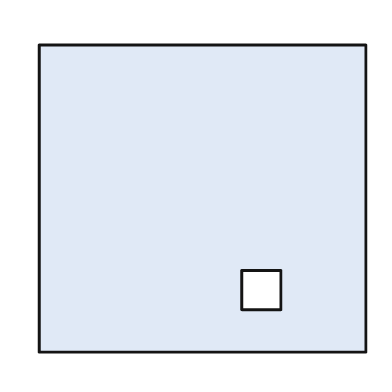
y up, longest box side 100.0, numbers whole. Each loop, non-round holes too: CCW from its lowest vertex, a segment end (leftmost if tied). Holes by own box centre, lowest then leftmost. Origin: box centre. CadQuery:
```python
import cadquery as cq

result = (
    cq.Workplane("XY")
    .moveTo(-50.0, -47.0)
    .lineTo(50.0, -47.0)
    .lineTo(50.0, 47.0)
    .lineTo(-50.0, 47.0)
    .close()
    .moveTo(12.0, -34.0)
    .lineTo(24.0, -34.0)
    .lineTo(24.0, -22.0)
    .lineTo(12.0, -22.0)
    .close()
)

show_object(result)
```